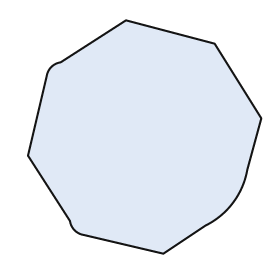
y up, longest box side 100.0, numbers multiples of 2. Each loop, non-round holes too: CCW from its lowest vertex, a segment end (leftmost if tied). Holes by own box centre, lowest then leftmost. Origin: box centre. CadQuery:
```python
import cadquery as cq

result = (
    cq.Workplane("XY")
    .moveTo(8.0, -50.0)
    .lineTo(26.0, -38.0)
    .threePointArc((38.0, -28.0), (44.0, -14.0))
    .lineTo(50.0, 8.0)
    .lineTo(30.0, 40.0)
    .lineTo(-8.0, 50.0)
    .lineTo(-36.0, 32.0)
    .threePointArc((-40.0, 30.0), (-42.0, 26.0))
    .lineTo(-50.0, -8.0)
    .lineTo(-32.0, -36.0)
    .threePointArc((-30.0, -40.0), (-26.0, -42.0))
    .close()
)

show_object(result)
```